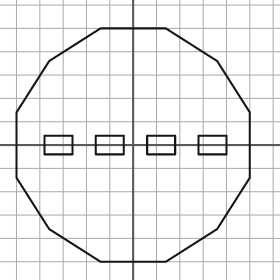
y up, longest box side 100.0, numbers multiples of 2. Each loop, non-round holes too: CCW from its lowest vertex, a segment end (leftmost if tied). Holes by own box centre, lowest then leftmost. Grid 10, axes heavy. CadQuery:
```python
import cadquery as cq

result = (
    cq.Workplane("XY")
    .moveTo(-14.0, -50.0)
    .lineTo(14.0, -50.0)
    .lineTo(36.0, -36.0)
    .lineTo(50.0, -14.0)
    .lineTo(50.0, 14.0)
    .lineTo(36.0, 36.0)
    .lineTo(14.0, 50.0)
    .lineTo(-14.0, 50.0)
    .lineTo(-36.0, 36.0)
    .lineTo(-50.0, 14.0)
    .lineTo(-50.0, -14.0)
    .lineTo(-36.0, -36.0)
    .close()
    .moveTo(-38.0, -4.0)
    .lineTo(-26.0, -4.0)
    .lineTo(-26.0, 4.0)
    .lineTo(-38.0, 4.0)
    .close()
    .moveTo(-16.0, -4.0)
    .lineTo(-4.0, -4.0)
    .lineTo(-4.0, 4.0)
    .lineTo(-16.0, 4.0)
    .close()
    .moveTo(6.0, -4.0)
    .lineTo(18.0, -4.0)
    .lineTo(18.0, 4.0)
    .lineTo(6.0, 4.0)
    .close()
    .moveTo(28.0, -4.0)
    .lineTo(40.0, -4.0)
    .lineTo(40.0, 4.0)
    .lineTo(28.0, 4.0)
    .close()
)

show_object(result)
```